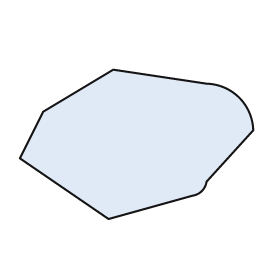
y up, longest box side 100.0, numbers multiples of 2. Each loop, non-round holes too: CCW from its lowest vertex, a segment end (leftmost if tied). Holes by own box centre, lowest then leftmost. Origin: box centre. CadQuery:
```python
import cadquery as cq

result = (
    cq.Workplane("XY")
    .moveTo(-12.0, -32.0)
    .lineTo(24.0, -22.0)
    .threePointArc((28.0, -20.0), (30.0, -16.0))
    .lineTo(50.0, 6.0)
    .threePointArc((44.0, 20.0), (30.0, 26.0))
    .lineTo(-10.0, 32.0)
    .lineTo(-40.0, 14.0)
    .lineTo(-50.0, -6.0)
    .close()
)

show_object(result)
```